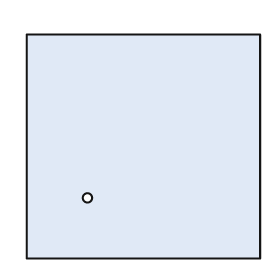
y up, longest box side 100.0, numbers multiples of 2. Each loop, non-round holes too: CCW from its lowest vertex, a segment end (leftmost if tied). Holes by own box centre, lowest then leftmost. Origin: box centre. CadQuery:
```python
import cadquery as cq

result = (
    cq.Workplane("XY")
    .moveTo(-50.0, -48.0)
    .lineTo(50.0, -48.0)
    .lineTo(50.0, 48.0)
    .lineTo(-50.0, 48.0)
    .close()
    .moveTo(-24.0, -22.0)
    .circle(2.0)
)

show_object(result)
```